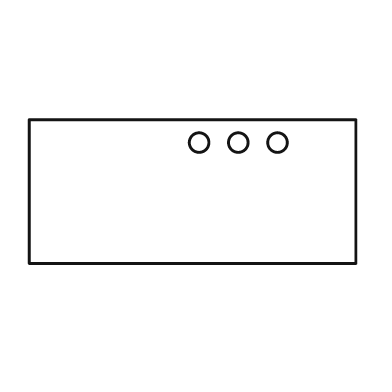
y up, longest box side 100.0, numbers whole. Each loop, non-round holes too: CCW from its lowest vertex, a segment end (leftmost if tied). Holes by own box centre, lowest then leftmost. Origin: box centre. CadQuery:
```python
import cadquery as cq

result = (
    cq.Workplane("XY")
    .moveTo(-50.0, -22.0)
    .lineTo(50.0, -22.0)
    .lineTo(50.0, 22.0)
    .lineTo(-50.0, 22.0)
    .close()
    .moveTo(2.0, 15.0)
    .circle(3.0)
    .moveTo(14.0, 15.0)
    .circle(3.0)
    .moveTo(26.0, 15.0)
    .circle(3.0)
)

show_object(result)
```